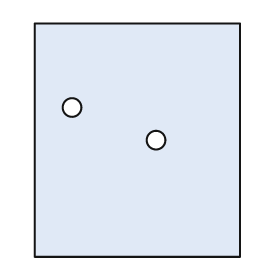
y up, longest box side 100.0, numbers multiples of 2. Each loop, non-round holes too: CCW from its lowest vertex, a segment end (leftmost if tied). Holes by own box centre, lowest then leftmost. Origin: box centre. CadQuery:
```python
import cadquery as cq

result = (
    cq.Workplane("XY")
    .moveTo(-44.0, -50.0)
    .lineTo(44.0, -50.0)
    .lineTo(44.0, 50.0)
    .lineTo(-44.0, 50.0)
    .close()
    .moveTo(8.0, 0.0)
    .circle(4.0)
    .moveTo(-28.0, 14.0)
    .circle(4.0)
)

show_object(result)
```